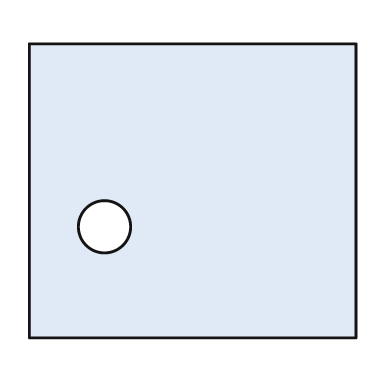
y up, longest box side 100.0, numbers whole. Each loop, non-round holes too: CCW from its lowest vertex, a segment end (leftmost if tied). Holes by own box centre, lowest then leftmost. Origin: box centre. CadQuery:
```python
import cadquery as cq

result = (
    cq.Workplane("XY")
    .moveTo(-50.0, -45.0)
    .lineTo(50.0, -45.0)
    .lineTo(50.0, 45.0)
    .lineTo(-50.0, 45.0)
    .close()
    .moveTo(-27.0, -11.0)
    .circle(8.0)
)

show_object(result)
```